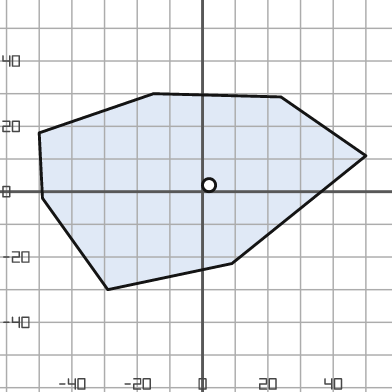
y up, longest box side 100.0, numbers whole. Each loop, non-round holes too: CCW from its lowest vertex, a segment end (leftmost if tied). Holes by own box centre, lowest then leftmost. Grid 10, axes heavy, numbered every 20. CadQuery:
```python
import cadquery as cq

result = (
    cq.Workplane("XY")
    .moveTo(-29.0, -30.0)
    .lineTo(9.0, -22.0)
    .lineTo(50.0, 11.0)
    .lineTo(24.0, 29.0)
    .lineTo(-15.0, 30.0)
    .lineTo(-50.0, 18.0)
    .lineTo(-49.0, -2.0)
    .close()
    .moveTo(2.0, 2.0)
    .circle(2.0)
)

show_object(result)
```